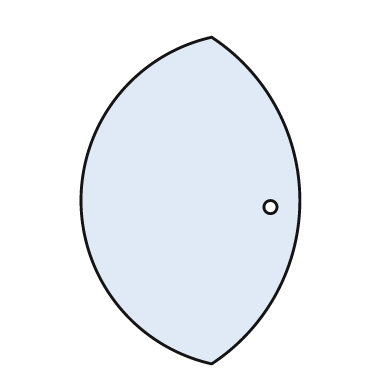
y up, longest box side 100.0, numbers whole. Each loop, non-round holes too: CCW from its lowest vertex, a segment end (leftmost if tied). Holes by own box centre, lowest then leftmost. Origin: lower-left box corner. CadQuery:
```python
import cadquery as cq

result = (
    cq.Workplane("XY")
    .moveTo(40.0, 0.0)
    .threePointArc((67.0, 50.0), (40.0, 100.0))
    .threePointArc((0.0, 50.0), (40.0, 0.0))
    .close()
    .moveTo(58.0, 48.0)
    .circle(2.0)
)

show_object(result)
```